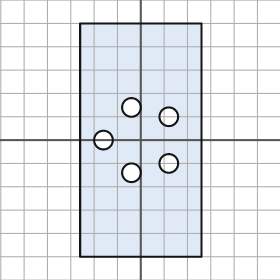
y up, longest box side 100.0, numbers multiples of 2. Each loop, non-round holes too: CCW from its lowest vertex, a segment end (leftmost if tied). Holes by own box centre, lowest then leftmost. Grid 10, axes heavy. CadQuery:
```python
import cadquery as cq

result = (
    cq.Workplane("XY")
    .moveTo(-26.0, -50.0)
    .lineTo(26.0, -50.0)
    .lineTo(26.0, 50.0)
    .lineTo(-26.0, 50.0)
    .close()
    .moveTo(-4.0, -14.0)
    .circle(4.0)
    .moveTo(12.0, -10.0)
    .circle(4.0)
    .moveTo(-16.0, 0.0)
    .circle(4.0)
    .moveTo(12.0, 10.0)
    .circle(4.0)
    .moveTo(-4.0, 14.0)
    .circle(4.0)
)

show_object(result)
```